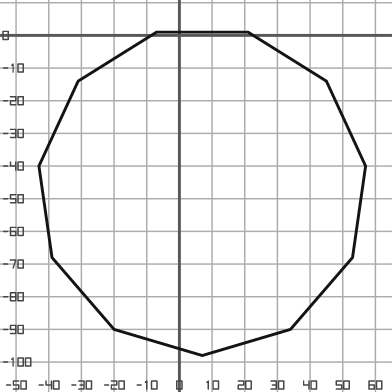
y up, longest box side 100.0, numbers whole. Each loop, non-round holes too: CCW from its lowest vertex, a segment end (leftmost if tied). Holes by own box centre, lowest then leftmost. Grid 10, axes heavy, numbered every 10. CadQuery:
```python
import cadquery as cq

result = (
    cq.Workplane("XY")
    .moveTo(7.0, -98.0)
    .lineTo(34.0, -90.0)
    .lineTo(53.0, -68.0)
    .lineTo(57.0, -40.0)
    .lineTo(45.0, -14.0)
    .lineTo(21.0, 1.0)
    .lineTo(-7.0, 1.0)
    .lineTo(-31.0, -14.0)
    .lineTo(-43.0, -40.0)
    .lineTo(-39.0, -68.0)
    .lineTo(-20.0, -90.0)
    .close()
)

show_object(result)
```